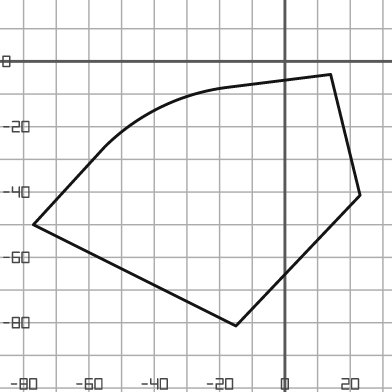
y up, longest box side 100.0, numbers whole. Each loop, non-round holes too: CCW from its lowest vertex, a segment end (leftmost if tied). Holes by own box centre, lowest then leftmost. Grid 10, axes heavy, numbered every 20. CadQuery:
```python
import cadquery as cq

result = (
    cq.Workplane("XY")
    .moveTo(-15.0, -81.0)
    .lineTo(23.0, -41.0)
    .lineTo(14.0, -4.0)
    .lineTo(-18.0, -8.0)
    .threePointArc((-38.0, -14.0), (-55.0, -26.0))
    .lineTo(-77.0, -50.0)
    .close()
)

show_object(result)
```